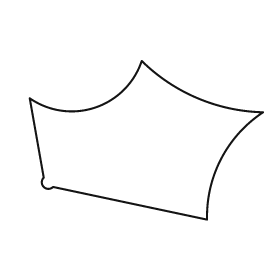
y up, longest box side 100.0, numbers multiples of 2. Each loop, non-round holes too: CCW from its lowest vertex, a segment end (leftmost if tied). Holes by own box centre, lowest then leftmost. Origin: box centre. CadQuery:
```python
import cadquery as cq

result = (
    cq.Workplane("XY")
    .moveTo(26.0, -34.0)
    .threePointArc((32.0, -8.0), (50.0, 12.0))
    .threePointArc((22.0, 18.0), (-2.0, 34.0))
    .threePointArc((-22.0, 14.0), (-50.0, 18.0))
    .lineTo(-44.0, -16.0)
    .threePointArc((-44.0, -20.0), (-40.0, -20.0))
    .close()
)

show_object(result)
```